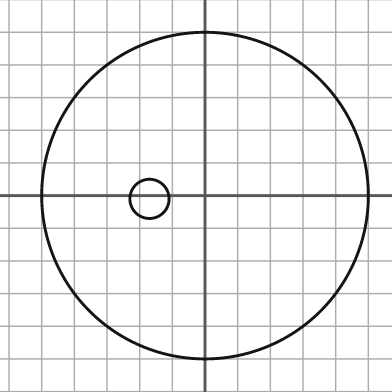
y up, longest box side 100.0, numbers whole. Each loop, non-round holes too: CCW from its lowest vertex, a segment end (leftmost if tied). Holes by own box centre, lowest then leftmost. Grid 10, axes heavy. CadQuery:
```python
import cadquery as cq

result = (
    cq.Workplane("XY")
    .moveTo(0.0, 0.0)
    .circle(50.0)
    .moveTo(-17.0, -1.0)
    .circle(6.0)
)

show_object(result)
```